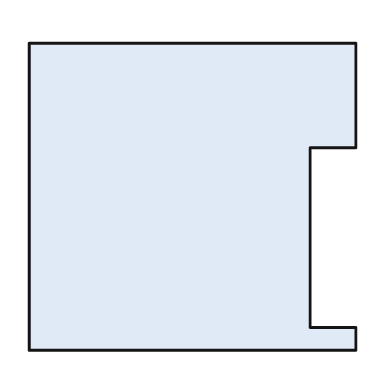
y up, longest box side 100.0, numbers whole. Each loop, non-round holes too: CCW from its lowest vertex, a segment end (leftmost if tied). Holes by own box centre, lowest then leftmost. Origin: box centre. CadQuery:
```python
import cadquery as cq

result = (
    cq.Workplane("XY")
    .moveTo(-50.0, -47.0)
    .lineTo(50.0, -47.0)
    .lineTo(50.0, -40.0)
    .lineTo(36.0, -40.0)
    .lineTo(36.0, 15.0)
    .lineTo(50.0, 15.0)
    .lineTo(50.0, 47.0)
    .lineTo(-50.0, 47.0)
    .close()
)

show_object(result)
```